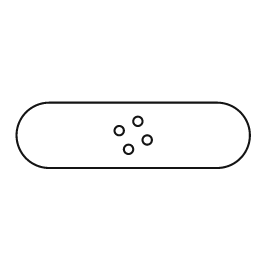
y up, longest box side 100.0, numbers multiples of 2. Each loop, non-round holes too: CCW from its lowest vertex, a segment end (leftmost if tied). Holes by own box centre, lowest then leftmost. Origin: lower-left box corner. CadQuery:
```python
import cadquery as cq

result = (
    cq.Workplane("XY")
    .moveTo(14.0, 0.0)
    .lineTo(86.0, 0.0)
    .threePointArc((100.0, 14.0), (86.0, 28.0))
    .lineTo(14.0, 28.0)
    .threePointArc((0.0, 14.0), (14.0, 0.0))
    .close()
    .moveTo(48.0, 8.0)
    .circle(2.0)
    .moveTo(56.0, 12.0)
    .circle(2.0)
    .moveTo(44.0, 16.0)
    .circle(2.0)
    .moveTo(52.0, 20.0)
    .circle(2.0)
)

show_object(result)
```